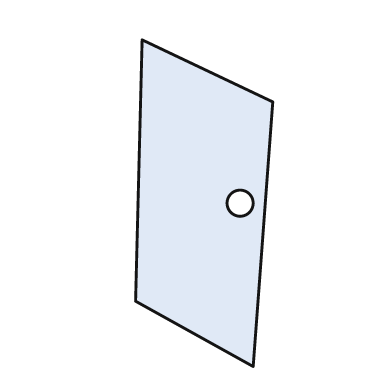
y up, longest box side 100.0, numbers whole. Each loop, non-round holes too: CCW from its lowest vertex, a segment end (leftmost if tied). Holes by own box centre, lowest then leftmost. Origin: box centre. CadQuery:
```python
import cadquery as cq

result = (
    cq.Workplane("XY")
    .moveTo(15.0, -50.0)
    .lineTo(21.0, 31.0)
    .lineTo(-19.0, 50.0)
    .lineTo(-21.0, -30.0)
    .close()
    .moveTo(11.0, 0.0)
    .circle(4.0)
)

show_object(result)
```